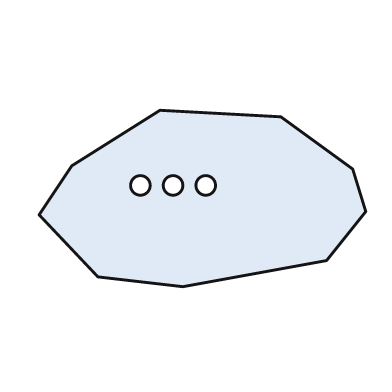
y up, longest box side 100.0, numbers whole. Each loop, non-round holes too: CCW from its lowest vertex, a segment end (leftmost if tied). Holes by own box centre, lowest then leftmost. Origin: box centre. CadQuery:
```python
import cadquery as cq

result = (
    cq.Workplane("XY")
    .moveTo(-6.0, -27.0)
    .lineTo(38.0, -19.0)
    .lineTo(50.0, -4.0)
    .lineTo(46.0, 9.0)
    .lineTo(24.0, 25.0)
    .lineTo(-13.0, 27.0)
    .lineTo(-40.0, 10.0)
    .lineTo(-50.0, -5.0)
    .lineTo(-32.0, -24.0)
    .close()
    .moveTo(-19.0, 4.0)
    .circle(3.0)
    .moveTo(-9.0, 4.0)
    .circle(3.0)
    .moveTo(1.0, 4.0)
    .circle(3.0)
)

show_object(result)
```